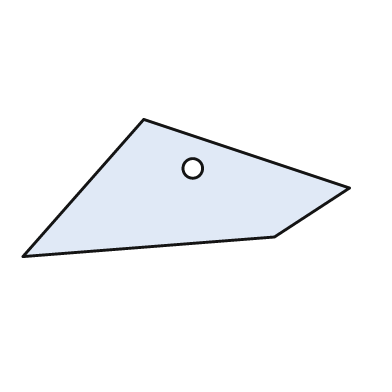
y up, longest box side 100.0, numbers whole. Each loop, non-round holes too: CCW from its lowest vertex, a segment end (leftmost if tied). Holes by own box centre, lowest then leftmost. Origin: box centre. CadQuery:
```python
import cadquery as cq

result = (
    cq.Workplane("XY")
    .moveTo(-50.0, -21.0)
    .lineTo(27.0, -15.0)
    .lineTo(50.0, 0.0)
    .lineTo(-13.0, 21.0)
    .close()
    .moveTo(2.0, 6.0)
    .circle(3.0)
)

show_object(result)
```